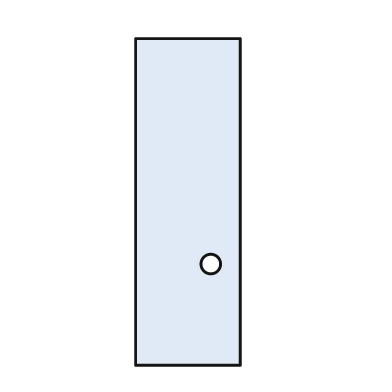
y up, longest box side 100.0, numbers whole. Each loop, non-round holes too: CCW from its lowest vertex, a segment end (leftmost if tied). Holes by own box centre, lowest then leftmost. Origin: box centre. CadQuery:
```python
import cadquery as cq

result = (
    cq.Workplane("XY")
    .moveTo(-16.0, -50.0)
    .lineTo(16.0, -50.0)
    .lineTo(16.0, 50.0)
    .lineTo(-16.0, 50.0)
    .close()
    .moveTo(7.0, -19.0)
    .circle(3.0)
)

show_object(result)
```